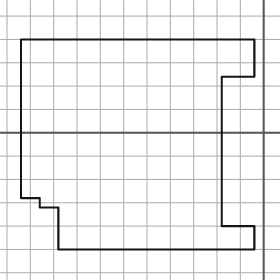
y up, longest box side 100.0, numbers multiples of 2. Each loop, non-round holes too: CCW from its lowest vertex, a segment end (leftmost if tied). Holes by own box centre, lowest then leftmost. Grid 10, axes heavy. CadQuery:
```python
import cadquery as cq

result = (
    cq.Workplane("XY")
    .moveTo(-88.0, -50.0)
    .lineTo(-4.0, -50.0)
    .lineTo(-4.0, -40.0)
    .lineTo(-18.0, -40.0)
    .lineTo(-18.0, 24.0)
    .lineTo(-4.0, 24.0)
    .lineTo(-4.0, 40.0)
    .lineTo(-104.0, 40.0)
    .lineTo(-104.0, -28.0)
    .lineTo(-96.0, -28.0)
    .lineTo(-96.0, -32.0)
    .lineTo(-88.0, -32.0)
    .close()
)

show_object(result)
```